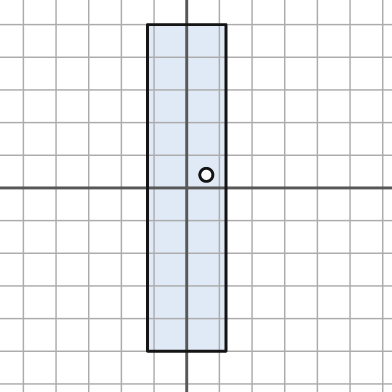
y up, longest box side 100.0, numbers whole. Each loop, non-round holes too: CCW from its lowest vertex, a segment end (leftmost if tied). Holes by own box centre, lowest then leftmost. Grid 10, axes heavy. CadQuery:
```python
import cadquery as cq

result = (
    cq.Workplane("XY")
    .moveTo(-12.0, -50.0)
    .lineTo(12.0, -50.0)
    .lineTo(12.0, 50.0)
    .lineTo(-12.0, 50.0)
    .close()
    .moveTo(6.0, 4.0)
    .circle(2.0)
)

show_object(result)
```